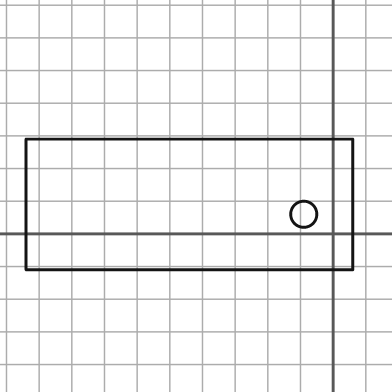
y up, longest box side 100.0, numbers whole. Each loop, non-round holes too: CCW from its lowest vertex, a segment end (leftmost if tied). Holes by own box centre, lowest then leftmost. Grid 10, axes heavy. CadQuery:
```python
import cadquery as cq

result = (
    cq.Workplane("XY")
    .moveTo(-94.0, -11.0)
    .lineTo(6.0, -11.0)
    .lineTo(6.0, 29.0)
    .lineTo(-94.0, 29.0)
    .close()
    .moveTo(-9.0, 6.0)
    .circle(4.0)
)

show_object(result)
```